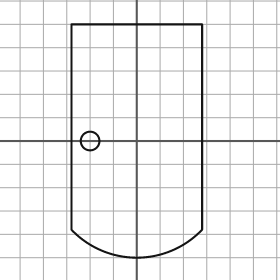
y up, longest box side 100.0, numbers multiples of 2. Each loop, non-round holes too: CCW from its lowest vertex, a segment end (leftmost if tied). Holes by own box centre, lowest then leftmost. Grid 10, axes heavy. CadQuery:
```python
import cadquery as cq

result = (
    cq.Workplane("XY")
    .moveTo(-28.0, -38.0)
    .threePointArc((0.0, -50.0), (28.0, -38.0))
    .lineTo(28.0, 50.0)
    .lineTo(-28.0, 50.0)
    .close()
    .moveTo(-20.0, 0.0)
    .circle(4.0)
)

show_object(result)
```